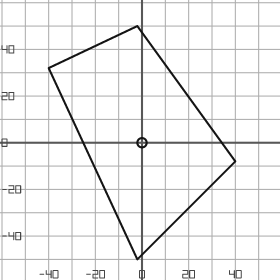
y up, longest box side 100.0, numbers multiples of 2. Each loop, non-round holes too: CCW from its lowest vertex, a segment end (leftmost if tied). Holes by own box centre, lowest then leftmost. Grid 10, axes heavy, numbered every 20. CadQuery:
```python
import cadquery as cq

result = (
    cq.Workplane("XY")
    .moveTo(-2.0, -50.0)
    .lineTo(40.0, -8.0)
    .lineTo(-2.0, 50.0)
    .lineTo(-40.0, 32.0)
    .close()
    .moveTo(0.0, 0.0)
    .circle(2.0)
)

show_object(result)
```